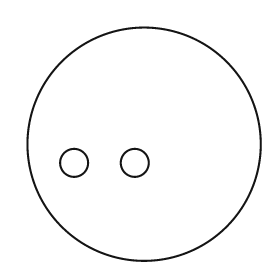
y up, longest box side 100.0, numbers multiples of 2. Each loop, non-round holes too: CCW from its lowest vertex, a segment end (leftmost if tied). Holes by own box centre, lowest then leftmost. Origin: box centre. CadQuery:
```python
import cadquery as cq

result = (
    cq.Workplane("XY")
    .moveTo(0.0, 0.0)
    .circle(50.0)
    .moveTo(-30.0, -8.0)
    .circle(6.0)
    .moveTo(-4.0, -8.0)
    .circle(6.0)
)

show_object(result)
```